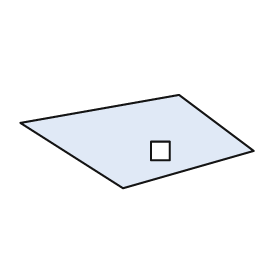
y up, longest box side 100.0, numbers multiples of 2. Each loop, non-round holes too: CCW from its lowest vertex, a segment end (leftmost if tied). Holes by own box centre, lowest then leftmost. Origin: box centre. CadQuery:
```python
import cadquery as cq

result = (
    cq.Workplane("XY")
    .moveTo(-6.0, -20.0)
    .lineTo(50.0, -4.0)
    .lineTo(18.0, 20.0)
    .lineTo(-50.0, 8.0)
    .close()
    .moveTo(6.0, -8.0)
    .lineTo(14.0, -8.0)
    .lineTo(14.0, 0.0)
    .lineTo(6.0, 0.0)
    .close()
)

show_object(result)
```